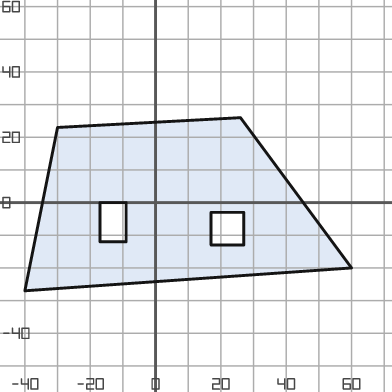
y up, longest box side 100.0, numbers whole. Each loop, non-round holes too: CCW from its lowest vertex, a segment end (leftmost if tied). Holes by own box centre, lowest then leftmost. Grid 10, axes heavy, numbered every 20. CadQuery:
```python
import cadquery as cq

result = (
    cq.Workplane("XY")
    .moveTo(-40.0, -27.0)
    .lineTo(60.0, -20.0)
    .lineTo(26.0, 26.0)
    .lineTo(-30.0, 23.0)
    .close()
    .moveTo(17.0, -13.0)
    .lineTo(27.0, -13.0)
    .lineTo(27.0, -3.0)
    .lineTo(17.0, -3.0)
    .close()
    .moveTo(-17.0, -12.0)
    .lineTo(-9.0, -12.0)
    .lineTo(-9.0, 0.0)
    .lineTo(-17.0, 0.0)
    .close()
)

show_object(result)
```